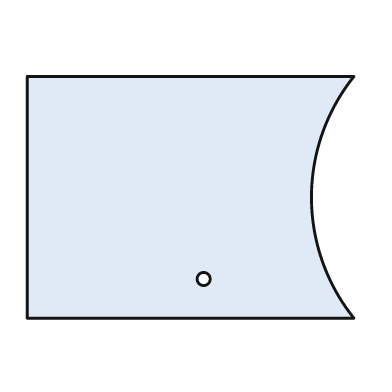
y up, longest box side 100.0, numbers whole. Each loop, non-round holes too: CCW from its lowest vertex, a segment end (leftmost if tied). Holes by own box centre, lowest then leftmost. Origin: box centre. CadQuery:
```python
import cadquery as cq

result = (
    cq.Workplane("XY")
    .moveTo(-50.0, -37.0)
    .lineTo(50.0, -37.0)
    .threePointArc((37.0, 0.0), (50.0, 37.0))
    .lineTo(-50.0, 37.0)
    .close()
    .moveTo(4.0, -25.0)
    .circle(2.0)
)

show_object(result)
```